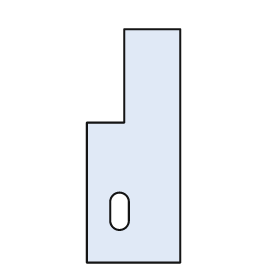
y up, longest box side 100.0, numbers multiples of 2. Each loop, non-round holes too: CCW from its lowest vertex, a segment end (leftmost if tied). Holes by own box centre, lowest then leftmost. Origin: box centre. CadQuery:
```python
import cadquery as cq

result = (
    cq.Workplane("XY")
    .moveTo(-20.0, -50.0)
    .lineTo(20.0, -50.0)
    .lineTo(20.0, 50.0)
    .lineTo(-4.0, 50.0)
    .lineTo(-4.0, 10.0)
    .lineTo(-20.0, 10.0)
    .close()
    .moveTo(-10.0, -32.0)
    .threePointArc((-6.0, -36.0), (-2.0, -32.0))
    .lineTo(-2.0, -24.0)
    .threePointArc((-6.0, -20.0), (-10.0, -24.0))
    .close()
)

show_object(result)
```